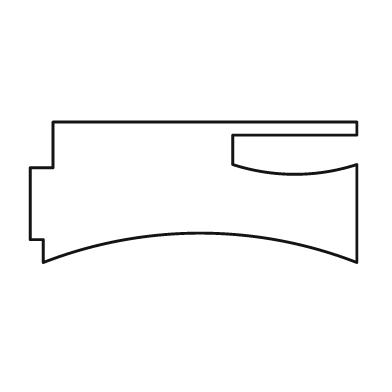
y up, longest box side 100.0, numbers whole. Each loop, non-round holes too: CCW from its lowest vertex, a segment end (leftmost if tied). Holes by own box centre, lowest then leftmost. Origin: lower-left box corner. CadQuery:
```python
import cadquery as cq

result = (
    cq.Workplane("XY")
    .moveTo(4.0, 0.0)
    .threePointArc((52.0, 9.0), (100.0, 0.0))
    .lineTo(100.0, 30.0)
    .threePointArc((81.0, 27.0), (62.0, 30.0))
    .lineTo(62.0, 39.0)
    .lineTo(100.0, 39.0)
    .lineTo(100.0, 43.0)
    .lineTo(7.0, 43.0)
    .lineTo(7.0, 29.0)
    .lineTo(0.0, 29.0)
    .lineTo(0.0, 7.0)
    .lineTo(4.0, 7.0)
    .close()
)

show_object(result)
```